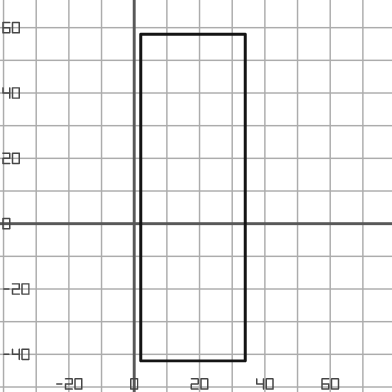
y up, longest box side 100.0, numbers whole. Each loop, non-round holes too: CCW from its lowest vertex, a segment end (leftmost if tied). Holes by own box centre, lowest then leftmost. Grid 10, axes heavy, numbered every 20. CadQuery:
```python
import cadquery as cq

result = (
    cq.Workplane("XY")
    .moveTo(2.0, -42.0)
    .lineTo(34.0, -42.0)
    .lineTo(34.0, 58.0)
    .lineTo(2.0, 58.0)
    .close()
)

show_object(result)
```